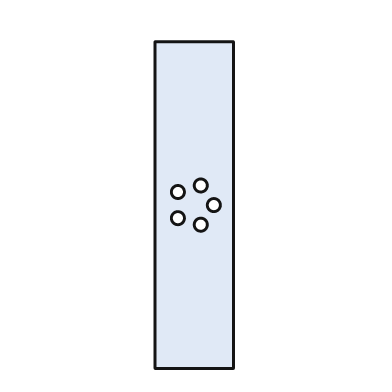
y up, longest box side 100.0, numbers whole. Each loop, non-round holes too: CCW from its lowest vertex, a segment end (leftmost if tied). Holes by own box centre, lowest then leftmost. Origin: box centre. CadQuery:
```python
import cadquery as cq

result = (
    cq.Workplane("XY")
    .moveTo(-12.0, -50.0)
    .lineTo(12.0, -50.0)
    .lineTo(12.0, 50.0)
    .lineTo(-12.0, 50.0)
    .close()
    .moveTo(2.0, -6.0)
    .circle(2.0)
    .moveTo(-5.0, -4.0)
    .circle(2.0)
    .moveTo(6.0, 0.0)
    .circle(2.0)
    .moveTo(-5.0, 4.0)
    .circle(2.0)
    .moveTo(2.0, 6.0)
    .circle(2.0)
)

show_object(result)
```